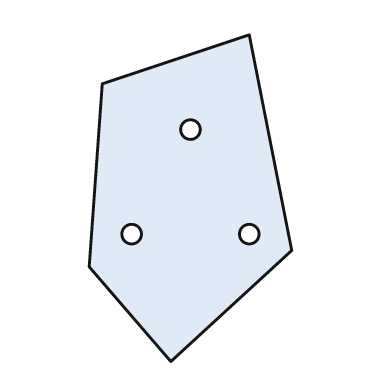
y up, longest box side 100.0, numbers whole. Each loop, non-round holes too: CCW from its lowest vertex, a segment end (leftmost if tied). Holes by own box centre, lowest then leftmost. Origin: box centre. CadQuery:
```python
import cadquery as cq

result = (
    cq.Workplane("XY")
    .moveTo(-6.0, -50.0)
    .lineTo(31.0, -16.0)
    .lineTo(18.0, 50.0)
    .lineTo(-27.0, 35.0)
    .lineTo(-31.0, -21.0)
    .close()
    .moveTo(-18.0, -11.0)
    .circle(3.0)
    .moveTo(18.0, -11.0)
    .circle(3.0)
    .moveTo(0.0, 21.0)
    .circle(3.0)
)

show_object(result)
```